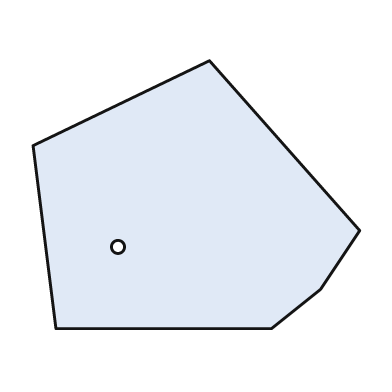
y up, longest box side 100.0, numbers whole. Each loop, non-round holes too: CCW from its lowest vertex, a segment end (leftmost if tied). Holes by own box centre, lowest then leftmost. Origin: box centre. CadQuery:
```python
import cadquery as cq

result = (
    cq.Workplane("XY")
    .moveTo(-43.0, -41.0)
    .lineTo(23.0, -41.0)
    .lineTo(38.0, -29.0)
    .lineTo(50.0, -11.0)
    .lineTo(4.0, 41.0)
    .lineTo(-50.0, 15.0)
    .close()
    .moveTo(-24.0, -16.0)
    .circle(2.0)
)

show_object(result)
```